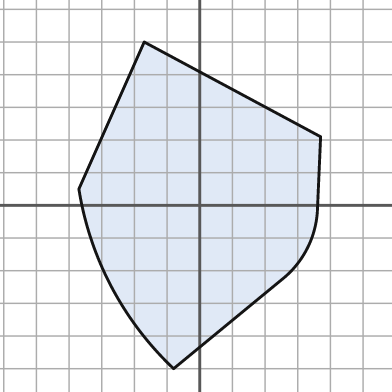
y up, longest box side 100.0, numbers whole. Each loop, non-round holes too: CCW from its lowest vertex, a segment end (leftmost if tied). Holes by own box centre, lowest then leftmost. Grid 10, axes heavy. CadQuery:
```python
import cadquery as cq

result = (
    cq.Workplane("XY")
    .moveTo(-8.0, -50.0)
    .lineTo(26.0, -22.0)
    .threePointArc((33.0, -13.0), (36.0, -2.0))
    .lineTo(37.0, 21.0)
    .lineTo(-17.0, 50.0)
    .lineTo(-37.0, 5.0)
    .threePointArc((-27.0, -25.0), (-8.0, -50.0))
    .close()
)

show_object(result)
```